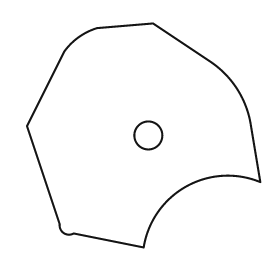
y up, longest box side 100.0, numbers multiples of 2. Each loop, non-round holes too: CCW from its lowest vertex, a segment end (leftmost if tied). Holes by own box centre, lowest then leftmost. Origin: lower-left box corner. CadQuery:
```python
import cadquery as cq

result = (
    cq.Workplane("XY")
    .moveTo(50.0, 0.0)
    .threePointArc((68.0, 26.0), (100.0, 28.0))
    .lineTo(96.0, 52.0)
    .threePointArc((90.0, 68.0), (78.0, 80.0))
    .lineTo(54.0, 96.0)
    .lineTo(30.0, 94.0)
    .threePointArc((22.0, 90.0), (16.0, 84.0))
    .lineTo(0.0, 52.0)
    .lineTo(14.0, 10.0)
    .threePointArc((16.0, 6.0), (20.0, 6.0))
    .close()
    .moveTo(52.0, 48.0)
    .circle(6.0)
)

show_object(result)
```